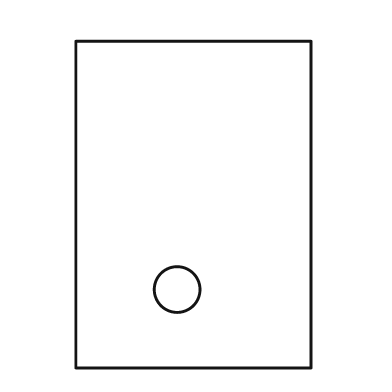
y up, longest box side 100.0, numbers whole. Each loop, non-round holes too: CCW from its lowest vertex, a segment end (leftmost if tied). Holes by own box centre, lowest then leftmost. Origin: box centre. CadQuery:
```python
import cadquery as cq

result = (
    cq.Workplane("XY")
    .moveTo(-36.0, -50.0)
    .lineTo(36.0, -50.0)
    .lineTo(36.0, 50.0)
    .lineTo(-36.0, 50.0)
    .close()
    .moveTo(-5.0, -26.0)
    .circle(7.0)
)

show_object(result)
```